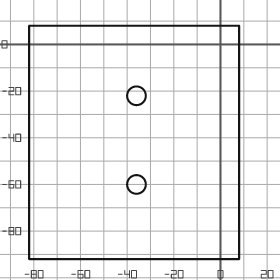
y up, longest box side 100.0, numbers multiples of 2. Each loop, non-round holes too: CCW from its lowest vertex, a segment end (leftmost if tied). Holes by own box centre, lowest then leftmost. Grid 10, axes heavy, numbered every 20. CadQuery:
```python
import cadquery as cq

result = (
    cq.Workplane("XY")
    .moveTo(-82.0, -92.0)
    .lineTo(8.0, -92.0)
    .lineTo(8.0, 8.0)
    .lineTo(-82.0, 8.0)
    .close()
    .moveTo(-36.0, -60.0)
    .circle(4.0)
    .moveTo(-36.0, -22.0)
    .circle(4.0)
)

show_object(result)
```